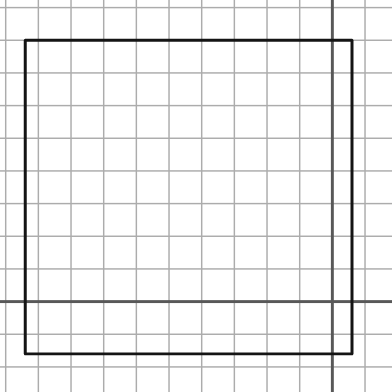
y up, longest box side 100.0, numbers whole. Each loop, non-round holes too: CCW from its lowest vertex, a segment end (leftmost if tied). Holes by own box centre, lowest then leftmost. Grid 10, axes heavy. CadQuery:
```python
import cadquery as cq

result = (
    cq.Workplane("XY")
    .moveTo(-94.0, -16.0)
    .lineTo(6.0, -16.0)
    .lineTo(6.0, 80.0)
    .lineTo(-94.0, 80.0)
    .close()
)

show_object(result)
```